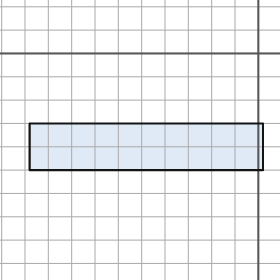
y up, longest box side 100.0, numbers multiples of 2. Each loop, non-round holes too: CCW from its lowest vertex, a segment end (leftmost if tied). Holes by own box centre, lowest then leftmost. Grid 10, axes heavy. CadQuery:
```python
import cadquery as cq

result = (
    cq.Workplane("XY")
    .moveTo(-98.0, -50.0)
    .lineTo(2.0, -50.0)
    .lineTo(2.0, -30.0)
    .lineTo(-98.0, -30.0)
    .close()
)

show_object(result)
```